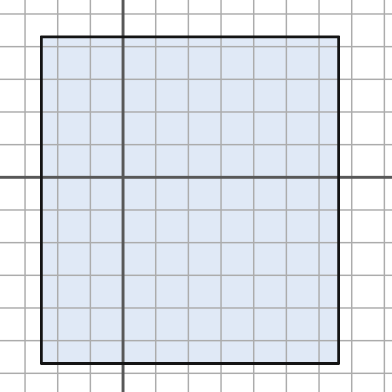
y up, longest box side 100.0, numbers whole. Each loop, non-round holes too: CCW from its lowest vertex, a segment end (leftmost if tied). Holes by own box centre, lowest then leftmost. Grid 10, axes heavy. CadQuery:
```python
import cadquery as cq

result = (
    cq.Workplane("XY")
    .moveTo(-25.0, -57.0)
    .lineTo(66.0, -57.0)
    .lineTo(66.0, 43.0)
    .lineTo(-25.0, 43.0)
    .close()
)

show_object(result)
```